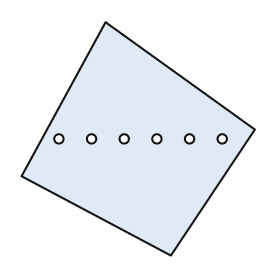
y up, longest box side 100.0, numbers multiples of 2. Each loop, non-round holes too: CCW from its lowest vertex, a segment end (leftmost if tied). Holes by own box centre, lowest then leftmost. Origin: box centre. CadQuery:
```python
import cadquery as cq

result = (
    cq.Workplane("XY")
    .moveTo(14.0, -50.0)
    .lineTo(50.0, 4.0)
    .lineTo(-14.0, 50.0)
    .lineTo(-50.0, -16.0)
    .close()
    .moveTo(-34.0, 0.0)
    .circle(2.0)
    .moveTo(-20.0, 0.0)
    .circle(2.0)
    .moveTo(-6.0, 0.0)
    .circle(2.0)
    .moveTo(8.0, 0.0)
    .circle(2.0)
    .moveTo(22.0, 0.0)
    .circle(2.0)
    .moveTo(36.0, 0.0)
    .circle(2.0)
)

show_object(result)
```